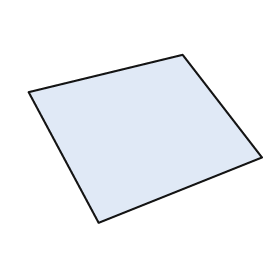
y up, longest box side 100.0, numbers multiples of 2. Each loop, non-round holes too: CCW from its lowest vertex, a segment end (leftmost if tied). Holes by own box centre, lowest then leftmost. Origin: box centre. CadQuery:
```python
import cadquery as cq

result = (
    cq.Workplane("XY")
    .moveTo(-20.0, -36.0)
    .lineTo(50.0, -8.0)
    .lineTo(16.0, 36.0)
    .lineTo(-50.0, 20.0)
    .close()
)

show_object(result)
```